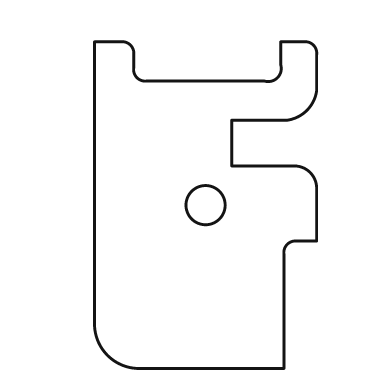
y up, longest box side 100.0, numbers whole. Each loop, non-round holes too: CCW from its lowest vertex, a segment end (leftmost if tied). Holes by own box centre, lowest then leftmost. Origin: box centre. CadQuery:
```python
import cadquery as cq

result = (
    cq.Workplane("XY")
    .moveTo(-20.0, -50.0)
    .lineTo(24.0, -50.0)
    .lineTo(24.0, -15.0)
    .threePointArc((25.0, -12.0), (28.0, -11.0))
    .lineTo(34.0, -11.0)
    .lineTo(34.0, 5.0)
    .threePointArc((32.0, 10.0), (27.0, 12.0))
    .lineTo(8.0, 12.0)
    .lineTo(8.0, 26.0)
    .lineTo(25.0, 26.0)
    .threePointArc((31.0, 29.0), (34.0, 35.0))
    .lineTo(34.0, 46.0)
    .threePointArc((33.0, 49.0), (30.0, 50.0))
    .lineTo(23.0, 50.0)
    .lineTo(23.0, 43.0)
    .threePointArc((22.0, 39.0), (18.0, 38.0))
    .lineTo(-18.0, 38.0)
    .threePointArc((-21.0, 39.0), (-22.0, 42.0))
    .lineTo(-22.0, 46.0)
    .threePointArc((-23.0, 49.0), (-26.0, 50.0))
    .lineTo(-34.0, 50.0)
    .lineTo(-34.0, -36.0)
    .threePointArc((-30.0, -46.0), (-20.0, -50.0))
    .close()
    .moveTo(0.0, 0.0)
    .circle(6.0)
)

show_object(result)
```